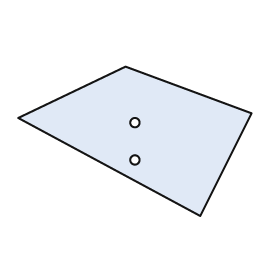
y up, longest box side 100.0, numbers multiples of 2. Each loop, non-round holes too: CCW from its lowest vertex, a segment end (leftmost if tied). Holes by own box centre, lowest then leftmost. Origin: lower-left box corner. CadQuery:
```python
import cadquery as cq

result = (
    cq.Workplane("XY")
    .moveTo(78.0, 0.0)
    .lineTo(100.0, 44.0)
    .lineTo(46.0, 64.0)
    .lineTo(0.0, 42.0)
    .close()
    .moveTo(50.0, 24.0)
    .circle(2.0)
    .moveTo(50.0, 40.0)
    .circle(2.0)
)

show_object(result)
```